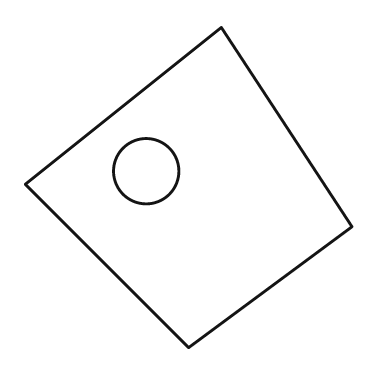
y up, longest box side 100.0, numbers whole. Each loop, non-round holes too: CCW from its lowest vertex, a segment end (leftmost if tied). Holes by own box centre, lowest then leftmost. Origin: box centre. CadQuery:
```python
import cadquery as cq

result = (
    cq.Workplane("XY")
    .moveTo(0.0, -49.0)
    .lineTo(50.0, -12.0)
    .lineTo(10.0, 49.0)
    .lineTo(-50.0, 1.0)
    .close()
    .moveTo(-13.0, 5.0)
    .circle(10.0)
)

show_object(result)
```